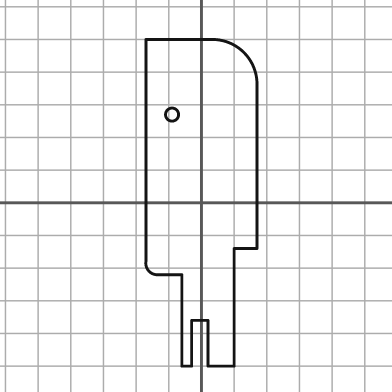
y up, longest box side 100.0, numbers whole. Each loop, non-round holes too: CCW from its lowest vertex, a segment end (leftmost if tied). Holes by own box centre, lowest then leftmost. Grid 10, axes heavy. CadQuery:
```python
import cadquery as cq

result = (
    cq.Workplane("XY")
    .moveTo(-6.0, -50.0)
    .lineTo(-3.0, -50.0)
    .lineTo(-3.0, -36.0)
    .lineTo(2.0, -36.0)
    .lineTo(2.0, -50.0)
    .lineTo(10.0, -50.0)
    .lineTo(10.0, -14.0)
    .lineTo(17.0, -14.0)
    .lineTo(17.0, 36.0)
    .threePointArc((13.0, 46.0), (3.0, 50.0))
    .lineTo(-17.0, 50.0)
    .lineTo(-17.0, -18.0)
    .threePointArc((-16.0, -21.0), (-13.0, -22.0))
    .lineTo(-6.0, -22.0)
    .close()
    .moveTo(-9.0, 27.0)
    .circle(2.0)
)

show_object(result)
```